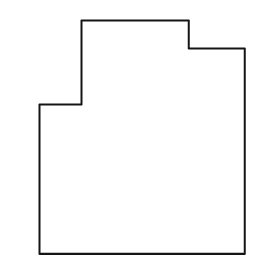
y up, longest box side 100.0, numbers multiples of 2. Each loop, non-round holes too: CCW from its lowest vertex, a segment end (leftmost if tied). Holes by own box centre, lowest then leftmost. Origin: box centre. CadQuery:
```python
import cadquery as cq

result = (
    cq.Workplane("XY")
    .moveTo(-44.0, -50.0)
    .lineTo(44.0, -50.0)
    .lineTo(44.0, 38.0)
    .lineTo(20.0, 38.0)
    .lineTo(20.0, 50.0)
    .lineTo(-26.0, 50.0)
    .lineTo(-26.0, 14.0)
    .lineTo(-44.0, 14.0)
    .close()
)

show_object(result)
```